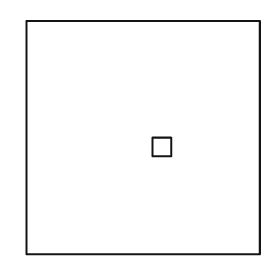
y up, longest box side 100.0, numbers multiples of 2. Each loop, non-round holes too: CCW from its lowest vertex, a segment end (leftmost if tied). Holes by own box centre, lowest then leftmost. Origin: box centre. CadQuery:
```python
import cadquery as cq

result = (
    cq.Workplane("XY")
    .moveTo(-50.0, -50.0)
    .lineTo(50.0, -50.0)
    .lineTo(50.0, 50.0)
    .lineTo(-50.0, 50.0)
    .close()
    .moveTo(4.0, -8.0)
    .lineTo(12.0, -8.0)
    .lineTo(12.0, 0.0)
    .lineTo(4.0, 0.0)
    .close()
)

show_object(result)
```